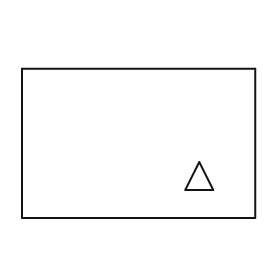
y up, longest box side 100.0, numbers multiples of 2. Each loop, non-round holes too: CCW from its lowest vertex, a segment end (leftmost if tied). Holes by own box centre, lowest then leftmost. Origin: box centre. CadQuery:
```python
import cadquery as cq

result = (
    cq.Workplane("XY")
    .moveTo(-50.0, -32.0)
    .lineTo(50.0, -32.0)
    .lineTo(50.0, 32.0)
    .lineTo(-50.0, 32.0)
    .close()
    .moveTo(20.0, -20.0)
    .lineTo(32.0, -20.0)
    .lineTo(26.0, -8.0)
    .close()
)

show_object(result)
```